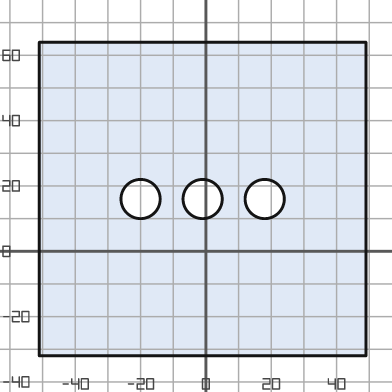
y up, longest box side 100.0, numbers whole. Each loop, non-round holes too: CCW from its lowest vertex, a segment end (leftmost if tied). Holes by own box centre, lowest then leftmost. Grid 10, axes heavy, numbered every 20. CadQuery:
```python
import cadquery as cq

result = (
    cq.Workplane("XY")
    .moveTo(-51.0, -32.0)
    .lineTo(49.0, -32.0)
    .lineTo(49.0, 64.0)
    .lineTo(-51.0, 64.0)
    .close()
    .moveTo(-20.0, 16.0)
    .circle(6.0)
    .moveTo(-1.0, 16.0)
    .circle(6.0)
    .moveTo(18.0, 16.0)
    .circle(6.0)
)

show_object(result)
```